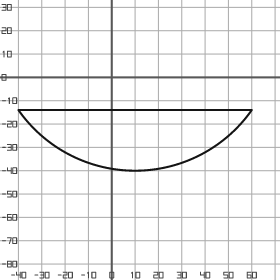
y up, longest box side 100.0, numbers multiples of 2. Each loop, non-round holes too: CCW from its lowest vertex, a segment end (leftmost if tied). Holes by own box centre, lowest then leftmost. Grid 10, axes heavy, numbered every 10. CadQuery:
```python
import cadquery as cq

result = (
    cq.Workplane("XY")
    .moveTo(-40.0, -14.0)
    .threePointArc((10.0, -40.0), (60.0, -14.0))
    .close()
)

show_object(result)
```